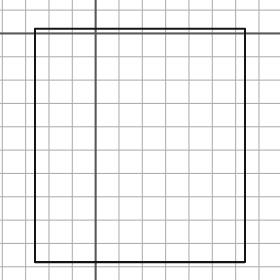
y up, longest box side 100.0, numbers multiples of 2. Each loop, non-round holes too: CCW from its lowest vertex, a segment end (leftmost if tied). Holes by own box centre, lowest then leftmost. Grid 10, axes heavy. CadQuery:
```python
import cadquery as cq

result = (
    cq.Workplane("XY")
    .moveTo(-26.0, -98.0)
    .lineTo(64.0, -98.0)
    .lineTo(64.0, 2.0)
    .lineTo(-26.0, 2.0)
    .close()
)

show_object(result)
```